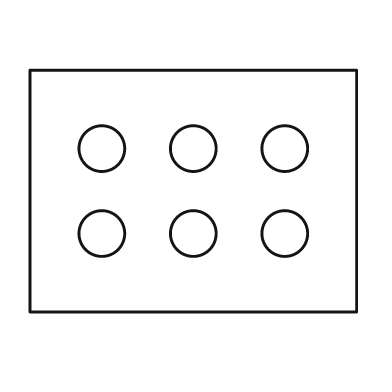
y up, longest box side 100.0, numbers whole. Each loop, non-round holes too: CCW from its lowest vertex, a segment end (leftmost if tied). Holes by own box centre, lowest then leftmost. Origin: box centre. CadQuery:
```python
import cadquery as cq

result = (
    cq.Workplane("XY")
    .moveTo(-50.0, -37.0)
    .lineTo(50.0, -37.0)
    .lineTo(50.0, 37.0)
    .lineTo(-50.0, 37.0)
    .close()
    .moveTo(-28.0, -13.0)
    .circle(7.0)
    .moveTo(0.0, -13.0)
    .circle(7.0)
    .moveTo(28.0, -13.0)
    .circle(7.0)
    .moveTo(-28.0, 13.0)
    .circle(7.0)
    .moveTo(0.0, 13.0)
    .circle(7.0)
    .moveTo(28.0, 13.0)
    .circle(7.0)
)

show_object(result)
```